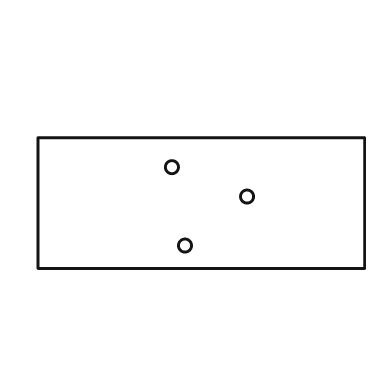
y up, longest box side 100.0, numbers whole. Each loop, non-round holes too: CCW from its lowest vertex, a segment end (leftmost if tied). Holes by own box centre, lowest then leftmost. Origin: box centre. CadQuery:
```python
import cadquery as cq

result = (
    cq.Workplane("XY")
    .moveTo(-50.0, -20.0)
    .lineTo(50.0, -20.0)
    .lineTo(50.0, 20.0)
    .lineTo(-50.0, 20.0)
    .close()
    .moveTo(-5.0, -13.0)
    .circle(2.0)
    .moveTo(14.0, 2.0)
    .circle(2.0)
    .moveTo(-9.0, 11.0)
    .circle(2.0)
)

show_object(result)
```